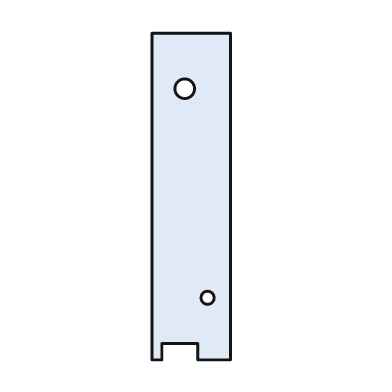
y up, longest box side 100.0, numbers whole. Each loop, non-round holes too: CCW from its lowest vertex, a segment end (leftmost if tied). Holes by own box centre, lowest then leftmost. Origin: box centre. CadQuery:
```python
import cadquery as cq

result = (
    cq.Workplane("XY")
    .moveTo(-12.0, -50.0)
    .lineTo(-9.0, -50.0)
    .lineTo(-9.0, -45.0)
    .lineTo(2.0, -45.0)
    .lineTo(2.0, -50.0)
    .lineTo(12.0, -50.0)
    .lineTo(12.0, 50.0)
    .lineTo(-12.0, 50.0)
    .close()
    .moveTo(5.0, -31.0)
    .circle(2.0)
    .moveTo(-2.0, 33.0)
    .circle(3.0)
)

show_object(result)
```